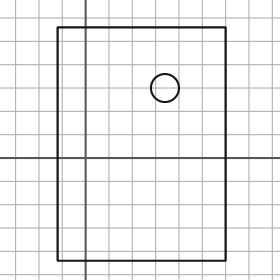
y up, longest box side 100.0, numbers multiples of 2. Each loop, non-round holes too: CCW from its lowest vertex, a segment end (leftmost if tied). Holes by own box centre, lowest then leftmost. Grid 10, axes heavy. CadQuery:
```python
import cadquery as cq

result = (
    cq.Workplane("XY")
    .moveTo(-12.0, -44.0)
    .lineTo(60.0, -44.0)
    .lineTo(60.0, 56.0)
    .lineTo(-12.0, 56.0)
    .close()
    .moveTo(34.0, 30.0)
    .circle(6.0)
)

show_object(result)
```